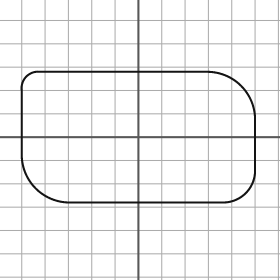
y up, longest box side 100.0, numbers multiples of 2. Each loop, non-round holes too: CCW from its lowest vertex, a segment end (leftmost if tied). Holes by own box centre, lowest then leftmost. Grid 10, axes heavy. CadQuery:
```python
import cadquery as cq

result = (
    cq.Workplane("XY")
    .moveTo(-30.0, -28.0)
    .lineTo(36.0, -28.0)
    .threePointArc((46.0, -24.0), (50.0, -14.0))
    .lineTo(50.0, 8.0)
    .threePointArc((44.0, 22.0), (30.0, 28.0))
    .lineTo(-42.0, 28.0)
    .threePointArc((-48.0, 26.0), (-50.0, 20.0))
    .lineTo(-50.0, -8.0)
    .threePointArc((-44.0, -22.0), (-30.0, -28.0))
    .close()
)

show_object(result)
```